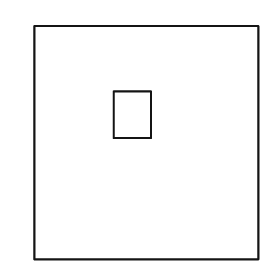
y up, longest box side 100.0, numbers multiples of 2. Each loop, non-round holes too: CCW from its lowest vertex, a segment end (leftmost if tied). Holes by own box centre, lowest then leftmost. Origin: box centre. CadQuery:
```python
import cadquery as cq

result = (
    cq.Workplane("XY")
    .moveTo(-48.0, -50.0)
    .lineTo(48.0, -50.0)
    .lineTo(48.0, 50.0)
    .lineTo(-48.0, 50.0)
    .close()
    .moveTo(-14.0, 2.0)
    .lineTo(2.0, 2.0)
    .lineTo(2.0, 22.0)
    .lineTo(-14.0, 22.0)
    .close()
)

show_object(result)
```